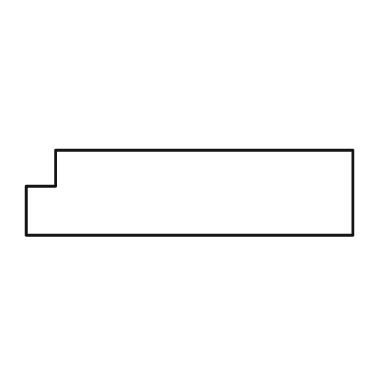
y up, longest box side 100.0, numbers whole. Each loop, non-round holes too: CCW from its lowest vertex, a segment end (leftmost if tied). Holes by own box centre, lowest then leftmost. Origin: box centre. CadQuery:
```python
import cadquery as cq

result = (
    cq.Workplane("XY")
    .moveTo(-50.0, -13.0)
    .lineTo(50.0, -13.0)
    .lineTo(50.0, 13.0)
    .lineTo(-41.0, 13.0)
    .lineTo(-41.0, 2.0)
    .lineTo(-50.0, 2.0)
    .close()
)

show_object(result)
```